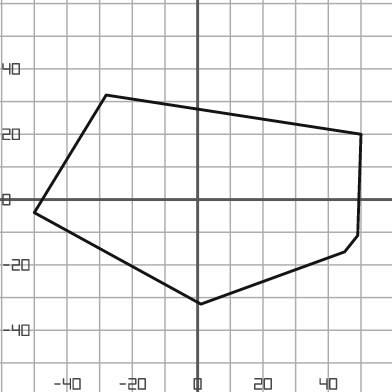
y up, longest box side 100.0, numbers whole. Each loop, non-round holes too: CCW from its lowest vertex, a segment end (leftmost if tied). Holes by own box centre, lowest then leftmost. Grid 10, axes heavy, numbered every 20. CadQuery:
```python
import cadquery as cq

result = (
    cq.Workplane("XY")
    .moveTo(1.0, -32.0)
    .lineTo(45.0, -16.0)
    .lineTo(49.0, -11.0)
    .lineTo(50.0, 20.0)
    .lineTo(-28.0, 32.0)
    .lineTo(-50.0, -4.0)
    .close()
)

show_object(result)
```